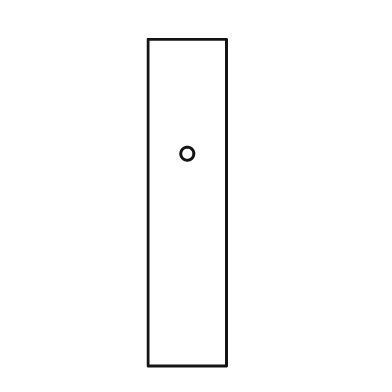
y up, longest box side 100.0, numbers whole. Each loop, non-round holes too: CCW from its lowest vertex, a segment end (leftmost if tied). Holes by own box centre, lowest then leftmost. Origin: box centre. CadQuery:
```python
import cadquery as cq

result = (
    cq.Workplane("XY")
    .moveTo(-12.0, -50.0)
    .lineTo(12.0, -50.0)
    .lineTo(12.0, 50.0)
    .lineTo(-12.0, 50.0)
    .close()
    .moveTo(0.0, 15.0)
    .circle(2.0)
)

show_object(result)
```